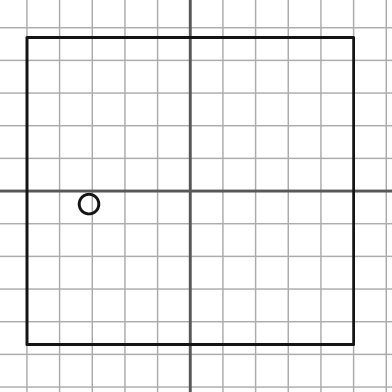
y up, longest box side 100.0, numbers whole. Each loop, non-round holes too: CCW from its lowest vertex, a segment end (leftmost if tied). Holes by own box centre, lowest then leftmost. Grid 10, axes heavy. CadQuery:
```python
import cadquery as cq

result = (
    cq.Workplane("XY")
    .moveTo(-50.0, -47.0)
    .lineTo(50.0, -47.0)
    .lineTo(50.0, 47.0)
    .lineTo(-50.0, 47.0)
    .close()
    .moveTo(-31.0, -4.0)
    .circle(3.0)
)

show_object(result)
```